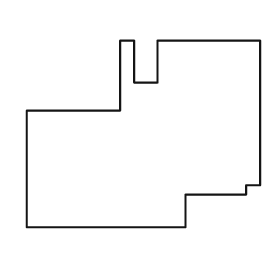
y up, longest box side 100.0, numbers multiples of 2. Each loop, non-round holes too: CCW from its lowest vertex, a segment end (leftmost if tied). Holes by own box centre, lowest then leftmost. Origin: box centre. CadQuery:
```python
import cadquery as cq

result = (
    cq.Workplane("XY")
    .moveTo(-50.0, -40.0)
    .lineTo(18.0, -40.0)
    .lineTo(18.0, -26.0)
    .lineTo(44.0, -26.0)
    .lineTo(44.0, -22.0)
    .lineTo(50.0, -22.0)
    .lineTo(50.0, 40.0)
    .lineTo(6.0, 40.0)
    .lineTo(6.0, 22.0)
    .lineTo(-4.0, 22.0)
    .lineTo(-4.0, 40.0)
    .lineTo(-10.0, 40.0)
    .lineTo(-10.0, 10.0)
    .lineTo(-50.0, 10.0)
    .close()
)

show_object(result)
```